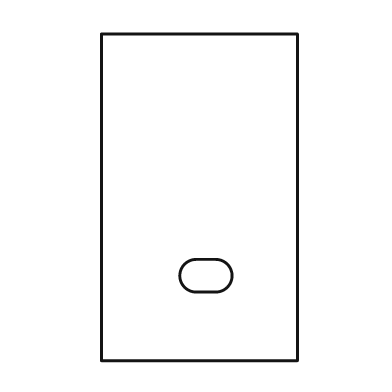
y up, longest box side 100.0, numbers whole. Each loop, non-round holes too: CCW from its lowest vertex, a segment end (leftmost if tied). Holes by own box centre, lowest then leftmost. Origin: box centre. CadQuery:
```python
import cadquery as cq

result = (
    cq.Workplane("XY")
    .moveTo(-30.0, -50.0)
    .lineTo(30.0, -50.0)
    .lineTo(30.0, 50.0)
    .lineTo(-30.0, 50.0)
    .close()
    .moveTo(-1.0, -29.0)
    .lineTo(5.0, -29.0)
    .threePointArc((10.0, -24.0), (5.0, -19.0))
    .lineTo(-1.0, -19.0)
    .threePointArc((-6.0, -24.0), (-1.0, -29.0))
    .close()
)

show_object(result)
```